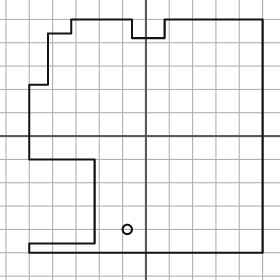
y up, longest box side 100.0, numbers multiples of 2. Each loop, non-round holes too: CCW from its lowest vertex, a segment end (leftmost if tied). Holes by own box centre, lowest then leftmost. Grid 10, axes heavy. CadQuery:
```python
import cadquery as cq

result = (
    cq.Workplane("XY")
    .moveTo(-50.0, -50.0)
    .lineTo(50.0, -50.0)
    .lineTo(50.0, 50.0)
    .lineTo(8.0, 50.0)
    .lineTo(8.0, 42.0)
    .lineTo(-6.0, 42.0)
    .lineTo(-6.0, 50.0)
    .lineTo(-32.0, 50.0)
    .lineTo(-32.0, 44.0)
    .lineTo(-42.0, 44.0)
    .lineTo(-42.0, 22.0)
    .lineTo(-50.0, 22.0)
    .lineTo(-50.0, -10.0)
    .lineTo(-22.0, -10.0)
    .lineTo(-22.0, -46.0)
    .lineTo(-50.0, -46.0)
    .close()
    .moveTo(-8.0, -40.0)
    .circle(2.0)
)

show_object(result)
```